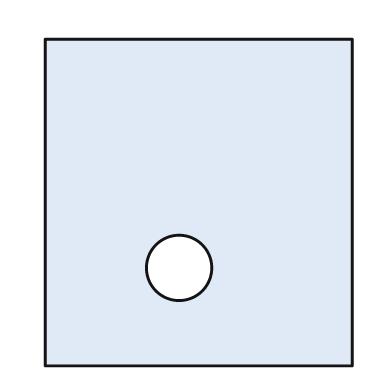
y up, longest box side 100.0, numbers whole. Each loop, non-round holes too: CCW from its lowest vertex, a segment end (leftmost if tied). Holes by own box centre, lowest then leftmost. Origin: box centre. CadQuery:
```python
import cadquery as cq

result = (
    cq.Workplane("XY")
    .moveTo(-47.0, -50.0)
    .lineTo(47.0, -50.0)
    .lineTo(47.0, 50.0)
    .lineTo(-47.0, 50.0)
    .close()
    .moveTo(-6.0, -20.0)
    .circle(10.0)
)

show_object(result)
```